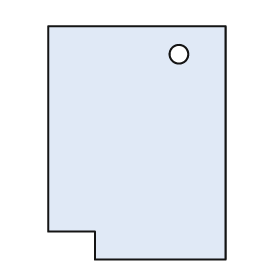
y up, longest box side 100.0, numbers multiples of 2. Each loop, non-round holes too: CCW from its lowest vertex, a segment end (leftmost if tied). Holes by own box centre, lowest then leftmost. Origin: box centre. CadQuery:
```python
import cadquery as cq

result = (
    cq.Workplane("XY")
    .moveTo(-18.0, -50.0)
    .lineTo(38.0, -50.0)
    .lineTo(38.0, 50.0)
    .lineTo(-38.0, 50.0)
    .lineTo(-38.0, -38.0)
    .lineTo(-18.0, -38.0)
    .close()
    .moveTo(18.0, 38.0)
    .circle(4.0)
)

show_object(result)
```